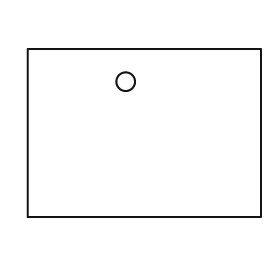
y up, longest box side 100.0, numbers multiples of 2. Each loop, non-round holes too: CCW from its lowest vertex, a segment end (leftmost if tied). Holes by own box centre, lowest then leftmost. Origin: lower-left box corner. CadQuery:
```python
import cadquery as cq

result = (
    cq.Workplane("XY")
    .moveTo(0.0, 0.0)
    .lineTo(100.0, 0.0)
    .lineTo(100.0, 72.0)
    .lineTo(0.0, 72.0)
    .close()
    .moveTo(42.0, 58.0)
    .circle(4.0)
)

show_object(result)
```